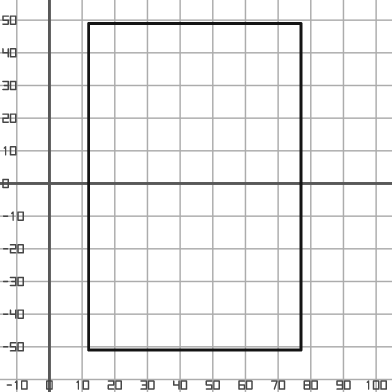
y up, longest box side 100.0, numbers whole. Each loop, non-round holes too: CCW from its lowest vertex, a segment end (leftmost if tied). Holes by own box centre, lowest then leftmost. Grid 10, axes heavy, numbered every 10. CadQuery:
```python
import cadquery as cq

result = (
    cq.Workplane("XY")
    .moveTo(12.0, -51.0)
    .lineTo(77.0, -51.0)
    .lineTo(77.0, 49.0)
    .lineTo(12.0, 49.0)
    .close()
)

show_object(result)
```